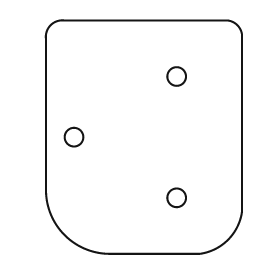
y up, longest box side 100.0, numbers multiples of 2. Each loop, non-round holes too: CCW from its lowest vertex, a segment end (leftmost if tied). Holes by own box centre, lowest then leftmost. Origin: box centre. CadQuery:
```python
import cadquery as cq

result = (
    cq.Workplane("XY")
    .moveTo(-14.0, -50.0)
    .lineTo(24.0, -50.0)
    .threePointArc((36.0, -44.0), (42.0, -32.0))
    .lineTo(42.0, 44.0)
    .threePointArc((40.0, 48.0), (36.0, 50.0))
    .lineTo(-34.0, 50.0)
    .threePointArc((-40.0, 48.0), (-42.0, 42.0))
    .lineTo(-42.0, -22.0)
    .threePointArc((-34.0, -42.0), (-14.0, -50.0))
    .close()
    .moveTo(14.0, -26.0)
    .circle(4.0)
    .moveTo(-30.0, 0.0)
    .circle(4.0)
    .moveTo(14.0, 26.0)
    .circle(4.0)
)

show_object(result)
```